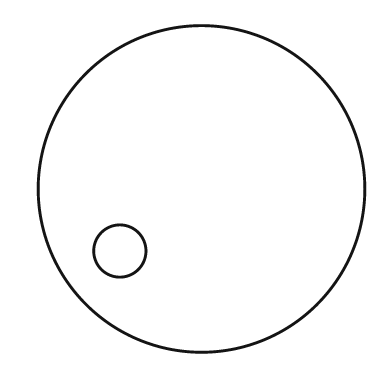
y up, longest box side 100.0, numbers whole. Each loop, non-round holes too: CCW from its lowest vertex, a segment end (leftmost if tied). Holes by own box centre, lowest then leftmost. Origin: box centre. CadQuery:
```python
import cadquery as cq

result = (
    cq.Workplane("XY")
    .moveTo(0.0, 0.0)
    .circle(50.0)
    .moveTo(-25.0, -19.0)
    .circle(8.0)
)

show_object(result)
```